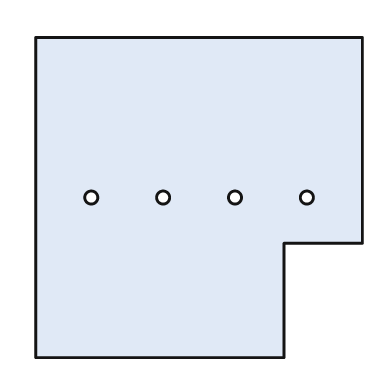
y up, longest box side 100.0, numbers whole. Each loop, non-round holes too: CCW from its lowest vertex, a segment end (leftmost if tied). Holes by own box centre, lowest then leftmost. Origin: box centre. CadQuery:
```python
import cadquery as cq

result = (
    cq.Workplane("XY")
    .moveTo(-50.0, -49.0)
    .lineTo(26.0, -49.0)
    .lineTo(26.0, -14.0)
    .lineTo(50.0, -14.0)
    .lineTo(50.0, 49.0)
    .lineTo(-50.0, 49.0)
    .close()
    .moveTo(-33.0, 0.0)
    .circle(2.0)
    .moveTo(-11.0, 0.0)
    .circle(2.0)
    .moveTo(11.0, 0.0)
    .circle(2.0)
    .moveTo(33.0, 0.0)
    .circle(2.0)
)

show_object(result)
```